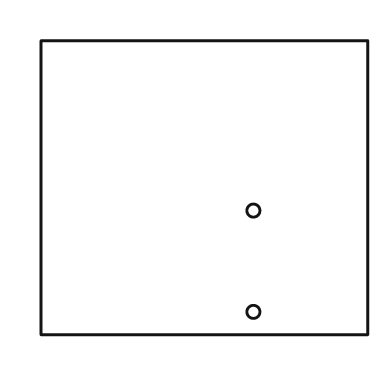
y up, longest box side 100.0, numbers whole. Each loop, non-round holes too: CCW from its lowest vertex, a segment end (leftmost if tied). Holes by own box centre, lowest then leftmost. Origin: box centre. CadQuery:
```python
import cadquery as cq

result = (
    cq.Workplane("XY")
    .moveTo(-50.0, -45.0)
    .lineTo(50.0, -45.0)
    .lineTo(50.0, 45.0)
    .lineTo(-50.0, 45.0)
    .close()
    .moveTo(15.0, -38.0)
    .circle(2.0)
    .moveTo(15.0, -7.0)
    .circle(2.0)
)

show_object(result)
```